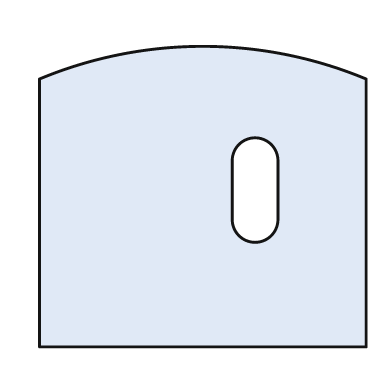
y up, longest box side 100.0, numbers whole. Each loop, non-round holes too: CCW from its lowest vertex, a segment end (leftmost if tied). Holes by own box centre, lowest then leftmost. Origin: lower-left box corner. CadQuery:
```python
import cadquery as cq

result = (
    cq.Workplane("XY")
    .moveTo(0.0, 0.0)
    .lineTo(100.0, 0.0)
    .lineTo(100.0, 82.0)
    .threePointArc((50.0, 92.0), (0.0, 82.0))
    .close()
    .moveTo(59.0, 39.0)
    .threePointArc((66.0, 32.0), (73.0, 39.0))
    .lineTo(73.0, 57.0)
    .threePointArc((66.0, 64.0), (59.0, 57.0))
    .close()
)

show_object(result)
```